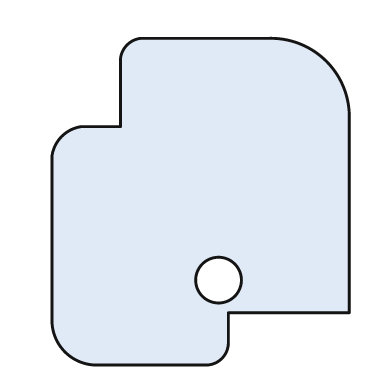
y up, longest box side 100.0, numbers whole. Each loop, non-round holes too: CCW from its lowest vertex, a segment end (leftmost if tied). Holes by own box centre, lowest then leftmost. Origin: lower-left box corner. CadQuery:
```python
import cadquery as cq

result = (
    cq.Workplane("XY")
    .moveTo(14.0, 0.0)
    .lineTo(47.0, 0.0)
    .threePointArc((52.0, 2.0), (54.0, 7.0))
    .lineTo(54.0, 16.0)
    .lineTo(91.0, 16.0)
    .lineTo(91.0, 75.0)
    .threePointArc((84.0, 93.0), (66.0, 100.0))
    .lineTo(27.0, 100.0)
    .threePointArc((23.0, 98.0), (21.0, 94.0))
    .lineTo(21.0, 73.0)
    .lineTo(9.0, 73.0)
    .threePointArc((3.0, 70.0), (0.0, 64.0))
    .lineTo(0.0, 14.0)
    .threePointArc((4.0, 4.0), (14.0, 0.0))
    .close()
    .moveTo(51.0, 26.0)
    .circle(7.0)
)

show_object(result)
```